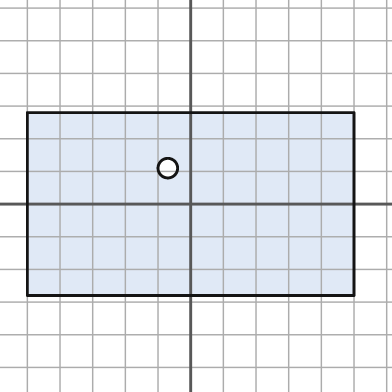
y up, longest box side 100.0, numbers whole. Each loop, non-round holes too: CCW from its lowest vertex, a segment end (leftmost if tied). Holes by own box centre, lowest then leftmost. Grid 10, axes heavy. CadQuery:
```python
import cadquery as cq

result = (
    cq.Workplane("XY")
    .moveTo(-50.0, -28.0)
    .lineTo(50.0, -28.0)
    .lineTo(50.0, 28.0)
    .lineTo(-50.0, 28.0)
    .close()
    .moveTo(-7.0, 11.0)
    .circle(3.0)
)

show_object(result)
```